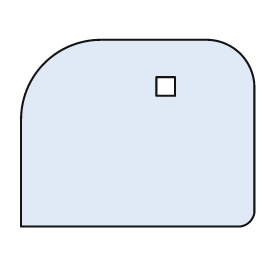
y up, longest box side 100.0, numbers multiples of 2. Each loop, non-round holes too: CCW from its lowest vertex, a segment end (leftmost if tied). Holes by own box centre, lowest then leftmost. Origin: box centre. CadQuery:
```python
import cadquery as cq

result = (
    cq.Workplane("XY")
    .moveTo(-50.0, -40.0)
    .lineTo(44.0, -40.0)
    .threePointArc((48.0, -38.0), (50.0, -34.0))
    .lineTo(50.0, 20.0)
    .threePointArc((44.0, 34.0), (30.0, 40.0))
    .lineTo(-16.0, 40.0)
    .threePointArc((-40.0, 30.0), (-50.0, 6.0))
    .close()
    .moveTo(8.0, 16.0)
    .lineTo(16.0, 16.0)
    .lineTo(16.0, 24.0)
    .lineTo(8.0, 24.0)
    .close()
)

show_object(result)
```